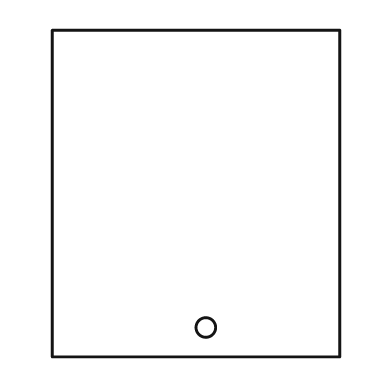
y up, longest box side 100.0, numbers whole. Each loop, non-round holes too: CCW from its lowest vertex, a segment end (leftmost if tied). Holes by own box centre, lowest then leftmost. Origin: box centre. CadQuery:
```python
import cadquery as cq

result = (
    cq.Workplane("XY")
    .moveTo(-44.0, -50.0)
    .lineTo(44.0, -50.0)
    .lineTo(44.0, 50.0)
    .lineTo(-44.0, 50.0)
    .close()
    .moveTo(3.0, -41.0)
    .circle(3.0)
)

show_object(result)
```